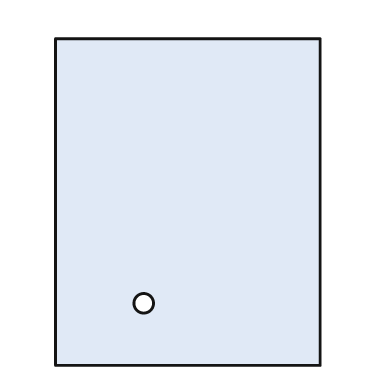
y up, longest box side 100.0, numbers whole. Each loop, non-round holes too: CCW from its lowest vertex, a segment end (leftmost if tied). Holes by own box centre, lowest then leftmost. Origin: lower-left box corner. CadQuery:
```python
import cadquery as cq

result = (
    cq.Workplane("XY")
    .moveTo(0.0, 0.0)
    .lineTo(81.0, 0.0)
    .lineTo(81.0, 100.0)
    .lineTo(0.0, 100.0)
    .close()
    .moveTo(27.0, 19.0)
    .circle(3.0)
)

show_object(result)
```